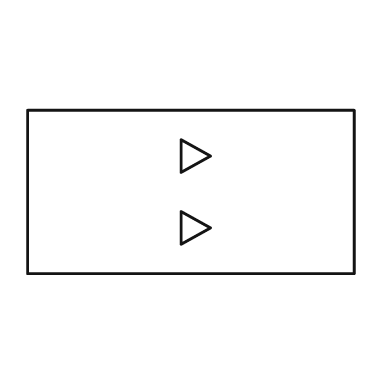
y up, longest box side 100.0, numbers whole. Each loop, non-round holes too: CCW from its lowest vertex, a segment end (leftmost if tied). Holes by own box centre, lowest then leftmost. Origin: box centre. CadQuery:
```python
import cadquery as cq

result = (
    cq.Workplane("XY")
    .moveTo(-50.0, -25.0)
    .lineTo(50.0, -25.0)
    .lineTo(50.0, 25.0)
    .lineTo(-50.0, 25.0)
    .close()
    .moveTo(-3.0, -16.0)
    .lineTo(6.0, -11.0)
    .lineTo(-3.0, -6.0)
    .close()
    .moveTo(-3.0, 6.0)
    .lineTo(6.0, 11.0)
    .lineTo(-3.0, 16.0)
    .close()
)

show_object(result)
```